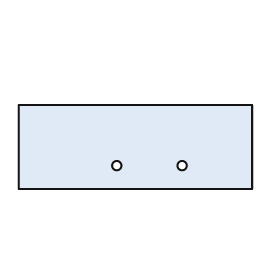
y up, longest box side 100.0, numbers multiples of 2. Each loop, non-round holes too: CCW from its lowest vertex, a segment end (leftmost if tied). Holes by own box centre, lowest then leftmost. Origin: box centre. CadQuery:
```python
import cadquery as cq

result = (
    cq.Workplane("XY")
    .moveTo(-50.0, -18.0)
    .lineTo(50.0, -18.0)
    .lineTo(50.0, 18.0)
    .lineTo(-50.0, 18.0)
    .close()
    .moveTo(-8.0, -8.0)
    .circle(2.0)
    .moveTo(20.0, -8.0)
    .circle(2.0)
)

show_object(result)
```